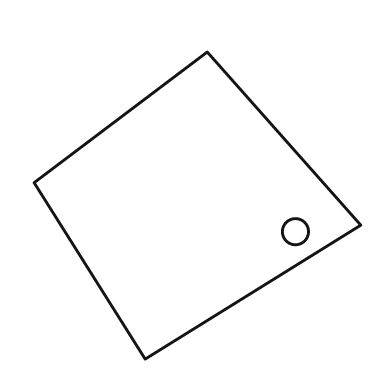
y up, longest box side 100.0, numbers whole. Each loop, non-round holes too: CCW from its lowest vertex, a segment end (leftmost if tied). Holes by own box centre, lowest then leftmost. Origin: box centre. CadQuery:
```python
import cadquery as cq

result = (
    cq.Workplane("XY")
    .moveTo(-16.0, -47.0)
    .lineTo(50.0, -6.0)
    .lineTo(3.0, 47.0)
    .lineTo(-50.0, 7.0)
    .close()
    .moveTo(30.0, -8.0)
    .circle(4.0)
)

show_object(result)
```